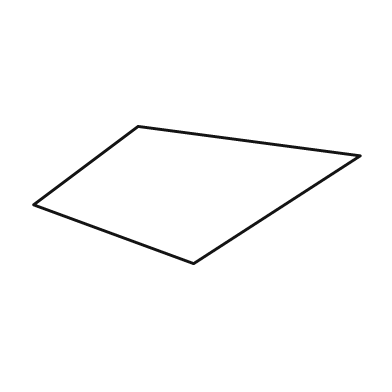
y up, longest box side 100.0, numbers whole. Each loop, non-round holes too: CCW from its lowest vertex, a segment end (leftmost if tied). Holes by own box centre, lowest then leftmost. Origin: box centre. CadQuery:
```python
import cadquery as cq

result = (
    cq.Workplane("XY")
    .moveTo(-1.0, -21.0)
    .lineTo(50.0, 12.0)
    .lineTo(-18.0, 21.0)
    .lineTo(-50.0, -3.0)
    .close()
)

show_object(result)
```